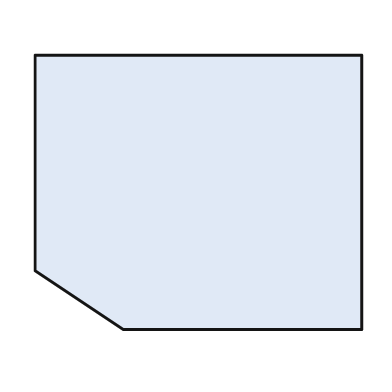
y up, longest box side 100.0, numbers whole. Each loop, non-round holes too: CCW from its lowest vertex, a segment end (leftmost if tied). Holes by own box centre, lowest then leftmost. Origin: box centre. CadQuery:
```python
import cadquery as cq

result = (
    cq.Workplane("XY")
    .moveTo(-23.0, -42.0)
    .lineTo(50.0, -42.0)
    .lineTo(50.0, 42.0)
    .lineTo(-50.0, 42.0)
    .lineTo(-50.0, -24.0)
    .close()
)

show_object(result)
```